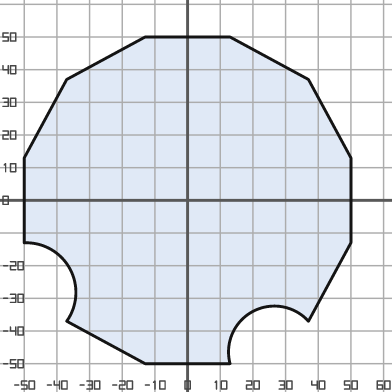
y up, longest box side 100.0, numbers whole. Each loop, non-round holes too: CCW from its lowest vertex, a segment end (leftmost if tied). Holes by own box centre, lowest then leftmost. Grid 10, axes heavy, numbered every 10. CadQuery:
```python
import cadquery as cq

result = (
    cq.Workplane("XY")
    .moveTo(-13.0, -50.0)
    .lineTo(13.0, -50.0)
    .threePointArc((20.0, -34.0), (37.0, -37.0))
    .lineTo(50.0, -13.0)
    .lineTo(50.0, 13.0)
    .lineTo(37.0, 37.0)
    .lineTo(13.0, 50.0)
    .lineTo(-13.0, 50.0)
    .lineTo(-37.0, 37.0)
    .lineTo(-50.0, 13.0)
    .lineTo(-50.0, -13.0)
    .threePointArc((-36.0, -21.0), (-37.0, -37.0))
    .close()
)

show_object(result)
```